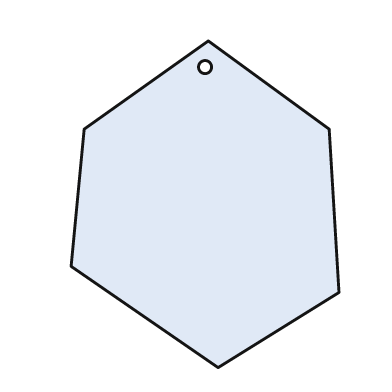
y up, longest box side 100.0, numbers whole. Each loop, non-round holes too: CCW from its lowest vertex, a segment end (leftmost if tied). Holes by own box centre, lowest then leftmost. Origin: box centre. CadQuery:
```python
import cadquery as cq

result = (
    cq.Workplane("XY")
    .moveTo(4.0, -50.0)
    .lineTo(41.0, -27.0)
    .lineTo(38.0, 23.0)
    .lineTo(1.0, 50.0)
    .lineTo(-37.0, 23.0)
    .lineTo(-41.0, -19.0)
    .close()
    .moveTo(0.0, 42.0)
    .circle(2.0)
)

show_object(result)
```